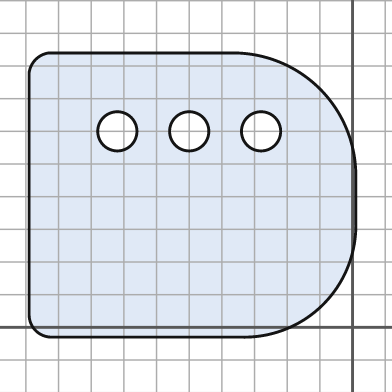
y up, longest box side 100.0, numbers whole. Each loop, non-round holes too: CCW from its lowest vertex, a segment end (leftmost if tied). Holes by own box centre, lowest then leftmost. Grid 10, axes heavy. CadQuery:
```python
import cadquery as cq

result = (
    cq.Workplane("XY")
    .moveTo(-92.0, -3.0)
    .lineTo(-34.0, -3.0)
    .threePointArc((-9.0, 7.0), (1.0, 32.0))
    .lineTo(1.0, 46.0)
    .threePointArc((-10.0, 73.0), (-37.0, 84.0))
    .lineTo(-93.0, 84.0)
    .threePointArc((-97.0, 82.0), (-99.0, 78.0))
    .lineTo(-99.0, 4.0)
    .threePointArc((-97.0, -1.0), (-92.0, -3.0))
    .close()
    .moveTo(-72.0, 60.0)
    .circle(6.0)
    .moveTo(-50.0, 60.0)
    .circle(6.0)
    .moveTo(-28.0, 60.0)
    .circle(6.0)
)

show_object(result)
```